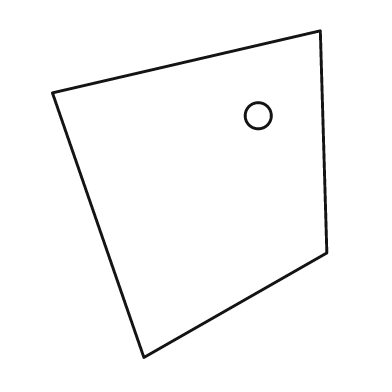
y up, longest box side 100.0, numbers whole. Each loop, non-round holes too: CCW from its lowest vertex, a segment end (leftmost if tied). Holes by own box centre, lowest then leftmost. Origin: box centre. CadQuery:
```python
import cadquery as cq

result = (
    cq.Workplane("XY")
    .moveTo(-14.0, -50.0)
    .lineTo(42.0, -18.0)
    .lineTo(40.0, 50.0)
    .lineTo(-42.0, 31.0)
    .close()
    .moveTo(21.0, 24.0)
    .circle(4.0)
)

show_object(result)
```